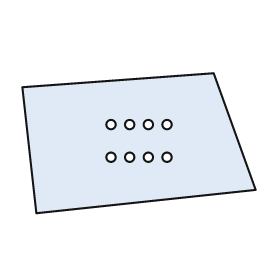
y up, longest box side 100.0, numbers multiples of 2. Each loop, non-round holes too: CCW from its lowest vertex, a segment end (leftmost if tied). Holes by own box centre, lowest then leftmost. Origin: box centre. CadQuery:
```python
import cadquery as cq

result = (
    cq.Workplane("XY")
    .moveTo(-44.0, -30.0)
    .lineTo(50.0, -20.0)
    .lineTo(32.0, 30.0)
    .lineTo(-50.0, 24.0)
    .close()
    .moveTo(-12.0, -6.0)
    .circle(2.0)
    .moveTo(-4.0, -6.0)
    .circle(2.0)
    .moveTo(4.0, -6.0)
    .circle(2.0)
    .moveTo(12.0, -6.0)
    .circle(2.0)
    .moveTo(-12.0, 8.0)
    .circle(2.0)
    .moveTo(-4.0, 8.0)
    .circle(2.0)
    .moveTo(4.0, 8.0)
    .circle(2.0)
    .moveTo(12.0, 8.0)
    .circle(2.0)
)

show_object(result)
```